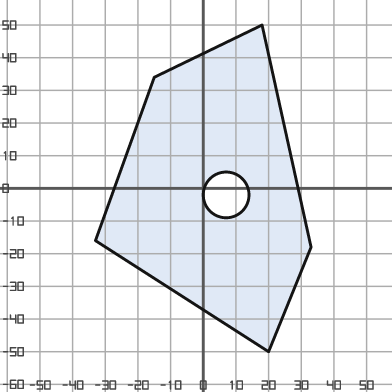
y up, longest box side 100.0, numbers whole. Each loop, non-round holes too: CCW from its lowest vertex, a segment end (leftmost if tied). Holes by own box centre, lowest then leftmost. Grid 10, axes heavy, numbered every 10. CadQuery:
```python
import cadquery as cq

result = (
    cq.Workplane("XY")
    .moveTo(20.0, -50.0)
    .lineTo(33.0, -18.0)
    .lineTo(18.0, 50.0)
    .lineTo(-15.0, 34.0)
    .lineTo(-33.0, -16.0)
    .close()
    .moveTo(7.0, -2.0)
    .circle(7.0)
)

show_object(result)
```